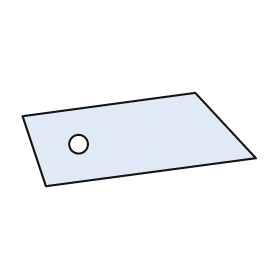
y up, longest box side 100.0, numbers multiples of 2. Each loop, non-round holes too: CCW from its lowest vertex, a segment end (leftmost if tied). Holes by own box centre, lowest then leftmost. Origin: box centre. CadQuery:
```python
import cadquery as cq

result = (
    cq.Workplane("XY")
    .moveTo(-40.0, -20.0)
    .lineTo(50.0, -8.0)
    .lineTo(24.0, 20.0)
    .lineTo(-50.0, 10.0)
    .close()
    .moveTo(-26.0, -2.0)
    .circle(4.0)
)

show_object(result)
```